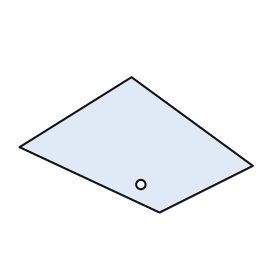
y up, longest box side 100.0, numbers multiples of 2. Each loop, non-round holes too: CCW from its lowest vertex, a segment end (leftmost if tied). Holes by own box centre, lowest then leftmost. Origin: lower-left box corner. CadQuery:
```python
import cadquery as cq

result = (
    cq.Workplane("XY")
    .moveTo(60.0, 0.0)
    .lineTo(100.0, 20.0)
    .lineTo(48.0, 58.0)
    .lineTo(0.0, 28.0)
    .close()
    .moveTo(52.0, 12.0)
    .circle(2.0)
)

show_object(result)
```